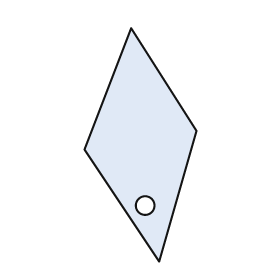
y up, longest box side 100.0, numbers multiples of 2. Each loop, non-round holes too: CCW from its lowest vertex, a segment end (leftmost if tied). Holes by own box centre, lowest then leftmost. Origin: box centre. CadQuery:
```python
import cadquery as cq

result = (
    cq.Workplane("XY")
    .moveTo(8.0, -50.0)
    .lineTo(24.0, 6.0)
    .lineTo(-4.0, 50.0)
    .lineTo(-24.0, -2.0)
    .close()
    .moveTo(2.0, -26.0)
    .circle(4.0)
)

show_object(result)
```